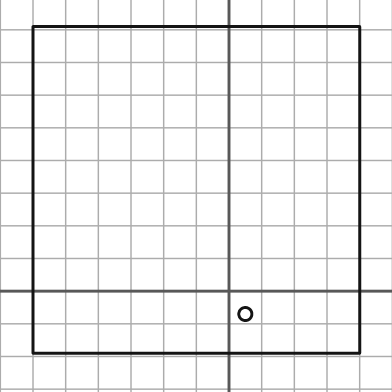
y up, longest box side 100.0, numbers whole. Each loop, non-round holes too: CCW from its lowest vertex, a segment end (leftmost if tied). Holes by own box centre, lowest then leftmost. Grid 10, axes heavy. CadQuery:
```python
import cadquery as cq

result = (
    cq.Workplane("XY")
    .moveTo(-60.0, -19.0)
    .lineTo(40.0, -19.0)
    .lineTo(40.0, 81.0)
    .lineTo(-60.0, 81.0)
    .close()
    .moveTo(5.0, -7.0)
    .circle(2.0)
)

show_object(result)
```